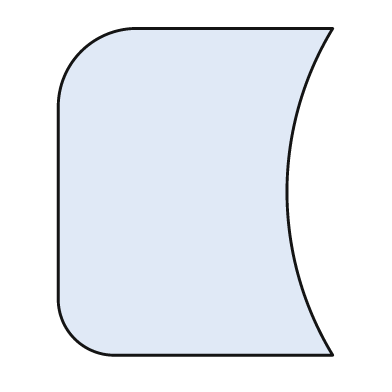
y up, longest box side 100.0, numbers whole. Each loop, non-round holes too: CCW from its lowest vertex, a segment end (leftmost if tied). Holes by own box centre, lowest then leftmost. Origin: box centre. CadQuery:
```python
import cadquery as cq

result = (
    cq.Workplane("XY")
    .moveTo(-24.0, -50.0)
    .lineTo(42.0, -50.0)
    .threePointArc((28.0, 0.0), (42.0, 50.0))
    .lineTo(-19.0, 50.0)
    .threePointArc((-35.0, 43.0), (-42.0, 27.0))
    .lineTo(-42.0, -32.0)
    .threePointArc((-37.0, -45.0), (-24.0, -50.0))
    .close()
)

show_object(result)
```